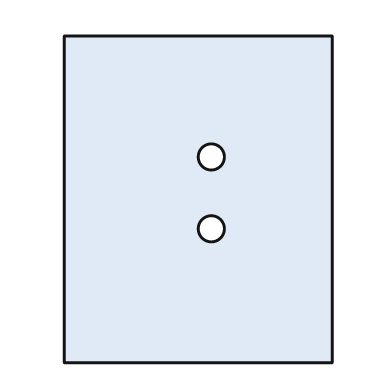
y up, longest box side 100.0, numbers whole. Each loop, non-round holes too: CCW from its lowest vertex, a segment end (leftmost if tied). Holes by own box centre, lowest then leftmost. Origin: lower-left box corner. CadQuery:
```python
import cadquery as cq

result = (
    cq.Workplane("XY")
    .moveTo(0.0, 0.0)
    .lineTo(82.0, 0.0)
    .lineTo(82.0, 100.0)
    .lineTo(0.0, 100.0)
    .close()
    .moveTo(45.0, 41.0)
    .circle(4.0)
    .moveTo(45.0, 63.0)
    .circle(4.0)
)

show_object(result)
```